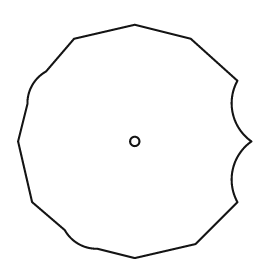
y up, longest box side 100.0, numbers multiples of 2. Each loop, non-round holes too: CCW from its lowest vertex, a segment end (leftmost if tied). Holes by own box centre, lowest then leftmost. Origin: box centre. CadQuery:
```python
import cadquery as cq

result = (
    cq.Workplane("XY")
    .moveTo(0.0, -50.0)
    .lineTo(26.0, -44.0)
    .lineTo(44.0, -26.0)
    .threePointArc((42.0, -12.0), (50.0, 0.0))
    .threePointArc((42.0, 12.0), (44.0, 26.0))
    .lineTo(24.0, 44.0)
    .lineTo(0.0, 50.0)
    .lineTo(-26.0, 44.0)
    .lineTo(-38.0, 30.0)
    .threePointArc((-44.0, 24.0), (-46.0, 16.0))
    .lineTo(-50.0, 0.0)
    .lineTo(-44.0, -26.0)
    .lineTo(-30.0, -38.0)
    .threePointArc((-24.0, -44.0), (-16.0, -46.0))
    .close()
    .moveTo(0.0, 0.0)
    .circle(2.0)
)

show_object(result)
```